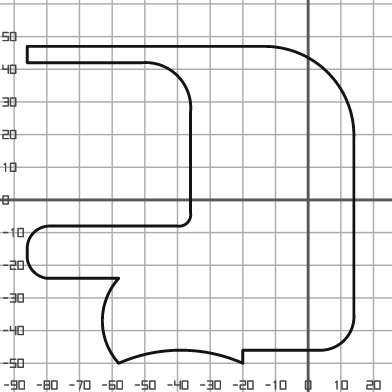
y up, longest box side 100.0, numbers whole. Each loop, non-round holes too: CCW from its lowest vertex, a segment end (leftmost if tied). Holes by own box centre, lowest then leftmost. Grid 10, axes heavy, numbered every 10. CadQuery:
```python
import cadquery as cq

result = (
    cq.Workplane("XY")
    .moveTo(-58.0, -50.0)
    .threePointArc((-39.0, -46.0), (-20.0, -50.0))
    .lineTo(-20.0, -46.0)
    .lineTo(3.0, -46.0)
    .threePointArc((11.0, -43.0), (14.0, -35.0))
    .lineTo(14.0, 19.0)
    .threePointArc((6.0, 39.0), (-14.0, 47.0))
    .lineTo(-86.0, 47.0)
    .lineTo(-86.0, 42.0)
    .lineTo(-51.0, 42.0)
    .threePointArc((-40.0, 38.0), (-36.0, 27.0))
    .lineTo(-36.0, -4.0)
    .threePointArc((-37.0, -7.0), (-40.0, -8.0))
    .lineTo(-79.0, -8.0)
    .threePointArc((-84.0, -10.0), (-86.0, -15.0))
    .lineTo(-86.0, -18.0)
    .threePointArc((-84.0, -22.0), (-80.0, -24.0))
    .lineTo(-58.0, -24.0)
    .threePointArc((-63.0, -37.0), (-58.0, -50.0))
    .close()
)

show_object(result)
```